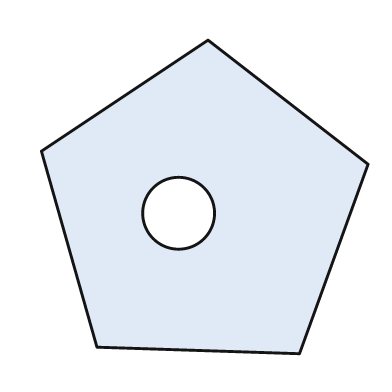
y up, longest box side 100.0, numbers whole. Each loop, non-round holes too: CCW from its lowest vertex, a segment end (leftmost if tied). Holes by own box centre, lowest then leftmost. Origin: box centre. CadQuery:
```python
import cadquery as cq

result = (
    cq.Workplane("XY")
    .moveTo(29.0, -48.0)
    .lineTo(50.0, 10.0)
    .lineTo(1.0, 48.0)
    .lineTo(-50.0, 14.0)
    .lineTo(-33.0, -46.0)
    .close()
    .moveTo(-8.0, -5.0)
    .circle(11.0)
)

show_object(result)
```